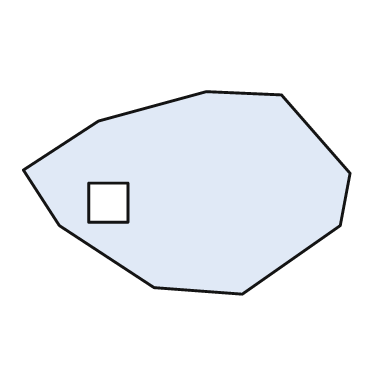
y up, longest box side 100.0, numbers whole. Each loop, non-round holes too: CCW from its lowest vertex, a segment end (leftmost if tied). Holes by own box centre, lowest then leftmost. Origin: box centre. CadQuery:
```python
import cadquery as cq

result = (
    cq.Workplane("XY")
    .moveTo(17.0, -31.0)
    .lineTo(47.0, -10.0)
    .lineTo(50.0, 6.0)
    .lineTo(29.0, 30.0)
    .lineTo(6.0, 31.0)
    .lineTo(-27.0, 22.0)
    .lineTo(-50.0, 7.0)
    .lineTo(-39.0, -10.0)
    .lineTo(-10.0, -29.0)
    .close()
    .moveTo(-30.0, -9.0)
    .lineTo(-18.0, -9.0)
    .lineTo(-18.0, 3.0)
    .lineTo(-30.0, 3.0)
    .close()
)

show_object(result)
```